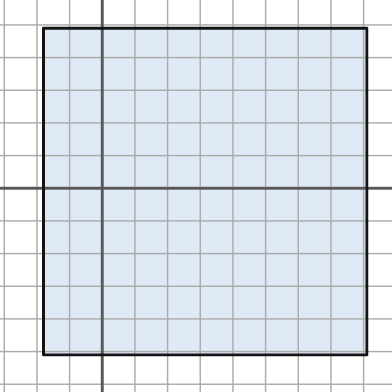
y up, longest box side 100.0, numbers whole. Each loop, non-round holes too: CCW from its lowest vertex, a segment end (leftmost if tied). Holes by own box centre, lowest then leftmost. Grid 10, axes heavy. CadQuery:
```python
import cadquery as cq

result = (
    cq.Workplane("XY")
    .moveTo(-18.0, -51.0)
    .lineTo(81.0, -51.0)
    .lineTo(81.0, 49.0)
    .lineTo(-18.0, 49.0)
    .close()
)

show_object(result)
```